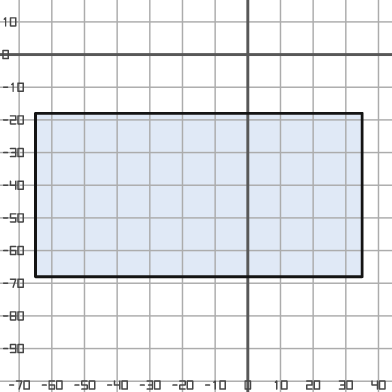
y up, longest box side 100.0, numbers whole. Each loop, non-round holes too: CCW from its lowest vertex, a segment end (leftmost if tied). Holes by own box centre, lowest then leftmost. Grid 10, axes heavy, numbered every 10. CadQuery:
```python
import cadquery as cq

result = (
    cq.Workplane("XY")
    .moveTo(-65.0, -68.0)
    .lineTo(35.0, -68.0)
    .lineTo(35.0, -18.0)
    .lineTo(-65.0, -18.0)
    .close()
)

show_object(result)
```